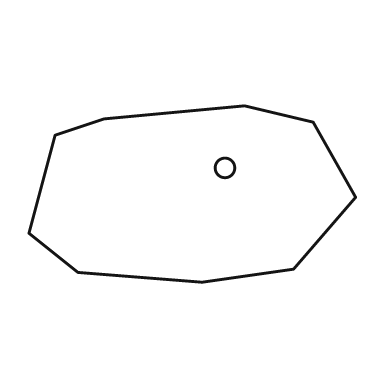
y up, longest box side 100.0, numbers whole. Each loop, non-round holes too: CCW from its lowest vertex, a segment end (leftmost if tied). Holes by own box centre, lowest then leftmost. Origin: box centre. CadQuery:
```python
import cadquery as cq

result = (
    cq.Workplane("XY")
    .moveTo(3.0, -27.0)
    .lineTo(31.0, -23.0)
    .lineTo(50.0, -1.0)
    .lineTo(37.0, 22.0)
    .lineTo(16.0, 27.0)
    .lineTo(-27.0, 23.0)
    .lineTo(-42.0, 18.0)
    .lineTo(-50.0, -12.0)
    .lineTo(-35.0, -24.0)
    .close()
    .moveTo(10.0, 8.0)
    .circle(3.0)
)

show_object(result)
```